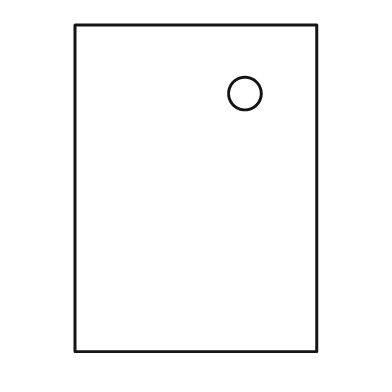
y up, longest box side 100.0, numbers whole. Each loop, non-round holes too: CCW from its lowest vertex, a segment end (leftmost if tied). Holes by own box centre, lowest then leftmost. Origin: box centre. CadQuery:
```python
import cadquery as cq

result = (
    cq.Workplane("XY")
    .moveTo(-37.0, -50.0)
    .lineTo(37.0, -50.0)
    .lineTo(37.0, 50.0)
    .lineTo(-37.0, 50.0)
    .close()
    .moveTo(15.0, 29.0)
    .circle(5.0)
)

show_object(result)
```